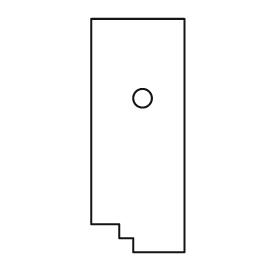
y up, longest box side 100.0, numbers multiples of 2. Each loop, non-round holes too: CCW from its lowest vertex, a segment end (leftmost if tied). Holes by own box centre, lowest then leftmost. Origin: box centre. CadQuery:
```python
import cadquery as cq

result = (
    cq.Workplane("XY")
    .moveTo(-2.0, -50.0)
    .lineTo(20.0, -50.0)
    .lineTo(20.0, 50.0)
    .lineTo(-20.0, 50.0)
    .lineTo(-20.0, -38.0)
    .lineTo(-8.0, -38.0)
    .lineTo(-8.0, -44.0)
    .lineTo(-2.0, -44.0)
    .close()
    .moveTo(2.0, 16.0)
    .circle(4.0)
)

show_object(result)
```